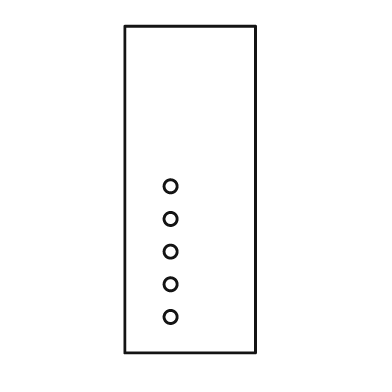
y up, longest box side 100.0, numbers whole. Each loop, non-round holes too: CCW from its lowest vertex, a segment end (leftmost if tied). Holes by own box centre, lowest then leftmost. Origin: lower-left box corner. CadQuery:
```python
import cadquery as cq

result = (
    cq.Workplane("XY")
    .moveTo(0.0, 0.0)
    .lineTo(40.0, 0.0)
    .lineTo(40.0, 100.0)
    .lineTo(0.0, 100.0)
    .close()
    .moveTo(14.0, 11.0)
    .circle(2.0)
    .moveTo(14.0, 21.0)
    .circle(2.0)
    .moveTo(14.0, 31.0)
    .circle(2.0)
    .moveTo(14.0, 41.0)
    .circle(2.0)
    .moveTo(14.0, 51.0)
    .circle(2.0)
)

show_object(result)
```